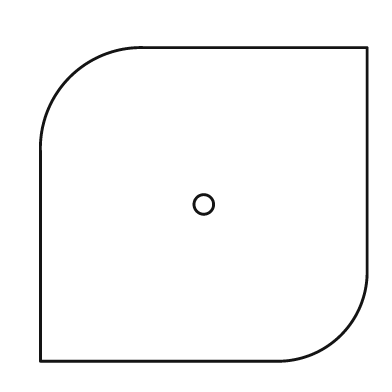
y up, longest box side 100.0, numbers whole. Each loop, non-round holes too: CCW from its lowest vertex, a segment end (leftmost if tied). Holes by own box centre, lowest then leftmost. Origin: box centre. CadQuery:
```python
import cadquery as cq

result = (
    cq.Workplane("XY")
    .moveTo(-50.0, -48.0)
    .lineTo(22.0, -48.0)
    .threePointArc((42.0, -40.0), (50.0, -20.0))
    .lineTo(50.0, 48.0)
    .lineTo(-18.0, 48.0)
    .threePointArc((-41.0, 39.0), (-50.0, 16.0))
    .close()
    .moveTo(0.0, 0.0)
    .circle(3.0)
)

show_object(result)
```